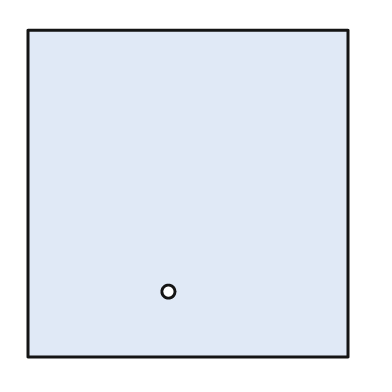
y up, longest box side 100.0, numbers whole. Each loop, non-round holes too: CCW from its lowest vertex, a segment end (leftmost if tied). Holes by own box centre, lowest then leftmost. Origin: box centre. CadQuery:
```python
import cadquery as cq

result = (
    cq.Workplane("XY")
    .moveTo(-49.0, -50.0)
    .lineTo(49.0, -50.0)
    .lineTo(49.0, 50.0)
    .lineTo(-49.0, 50.0)
    .close()
    .moveTo(-6.0, -30.0)
    .circle(2.0)
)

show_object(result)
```